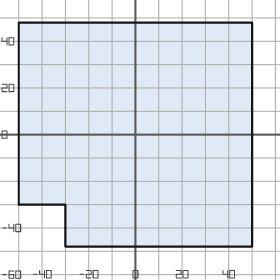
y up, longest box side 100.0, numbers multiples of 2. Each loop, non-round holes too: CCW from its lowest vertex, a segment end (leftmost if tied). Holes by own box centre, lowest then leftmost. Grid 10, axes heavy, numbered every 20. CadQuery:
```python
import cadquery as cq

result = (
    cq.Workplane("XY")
    .moveTo(-30.0, -48.0)
    .lineTo(50.0, -48.0)
    .lineTo(50.0, 48.0)
    .lineTo(-50.0, 48.0)
    .lineTo(-50.0, -30.0)
    .lineTo(-30.0, -30.0)
    .close()
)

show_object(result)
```